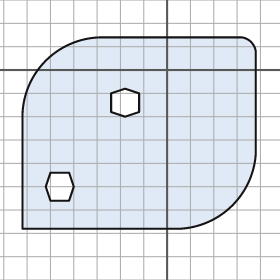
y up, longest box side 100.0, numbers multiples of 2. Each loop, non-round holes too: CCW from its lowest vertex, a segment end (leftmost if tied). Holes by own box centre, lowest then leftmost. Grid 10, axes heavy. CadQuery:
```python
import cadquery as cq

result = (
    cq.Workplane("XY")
    .moveTo(-62.0, -68.0)
    .lineTo(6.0, -68.0)
    .threePointArc((28.0, -58.0), (38.0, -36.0))
    .lineTo(38.0, 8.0)
    .threePointArc((36.0, 12.0), (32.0, 14.0))
    .lineTo(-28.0, 14.0)
    .threePointArc((-52.0, 4.0), (-62.0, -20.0))
    .close()
    .moveTo(-50.0, -56.0)
    .lineTo(-42.0, -56.0)
    .lineTo(-40.0, -50.0)
    .lineTo(-42.0, -44.0)
    .lineTo(-50.0, -44.0)
    .lineTo(-52.0, -50.0)
    .close()
    .moveTo(-18.0, -20.0)
    .lineTo(-12.0, -18.0)
    .lineTo(-12.0, -10.0)
    .lineTo(-18.0, -8.0)
    .lineTo(-24.0, -10.0)
    .lineTo(-24.0, -18.0)
    .close()
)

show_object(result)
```